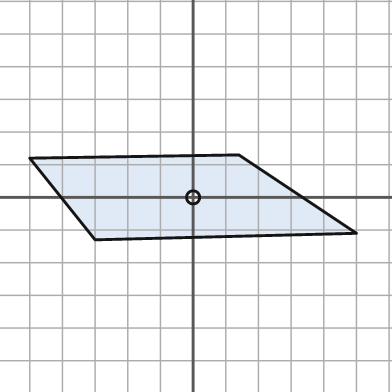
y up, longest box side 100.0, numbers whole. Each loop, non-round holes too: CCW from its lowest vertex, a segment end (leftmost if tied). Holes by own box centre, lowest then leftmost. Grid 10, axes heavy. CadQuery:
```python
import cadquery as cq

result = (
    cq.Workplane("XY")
    .moveTo(-30.0, -13.0)
    .lineTo(50.0, -11.0)
    .lineTo(14.0, 13.0)
    .lineTo(-50.0, 12.0)
    .close()
    .moveTo(0.0, 0.0)
    .circle(2.0)
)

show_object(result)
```